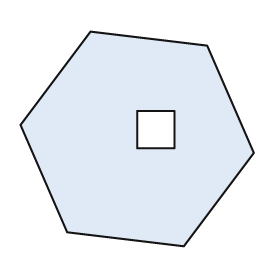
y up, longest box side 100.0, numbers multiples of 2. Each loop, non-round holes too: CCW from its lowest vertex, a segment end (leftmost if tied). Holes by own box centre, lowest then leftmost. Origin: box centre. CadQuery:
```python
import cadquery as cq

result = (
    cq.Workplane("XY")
    .moveTo(20.0, -46.0)
    .lineTo(50.0, -6.0)
    .lineTo(30.0, 40.0)
    .lineTo(-20.0, 46.0)
    .lineTo(-50.0, 6.0)
    .lineTo(-30.0, -40.0)
    .close()
    .moveTo(0.0, -4.0)
    .lineTo(16.0, -4.0)
    .lineTo(16.0, 12.0)
    .lineTo(0.0, 12.0)
    .close()
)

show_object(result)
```